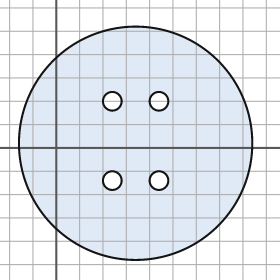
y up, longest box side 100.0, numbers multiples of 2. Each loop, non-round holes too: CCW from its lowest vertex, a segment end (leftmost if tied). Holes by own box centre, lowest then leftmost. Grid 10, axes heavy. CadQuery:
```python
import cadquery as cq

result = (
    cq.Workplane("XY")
    .moveTo(34.0, 2.0)
    .circle(50.0)
    .moveTo(24.0, -14.0)
    .circle(4.0)
    .moveTo(44.0, -14.0)
    .circle(4.0)
    .moveTo(24.0, 20.0)
    .circle(4.0)
    .moveTo(44.0, 20.0)
    .circle(4.0)
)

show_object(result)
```